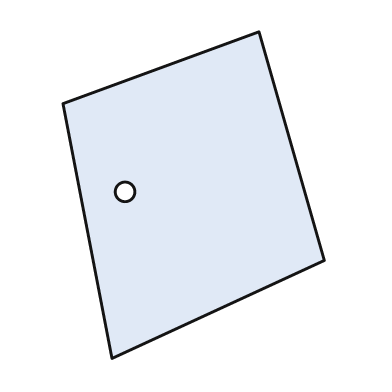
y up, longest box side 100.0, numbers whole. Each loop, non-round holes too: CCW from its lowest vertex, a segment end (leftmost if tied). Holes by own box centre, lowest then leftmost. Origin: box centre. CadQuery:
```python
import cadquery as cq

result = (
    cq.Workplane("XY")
    .moveTo(-25.0, -50.0)
    .lineTo(40.0, -20.0)
    .lineTo(20.0, 50.0)
    .lineTo(-40.0, 28.0)
    .close()
    .moveTo(-21.0, 1.0)
    .circle(3.0)
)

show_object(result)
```